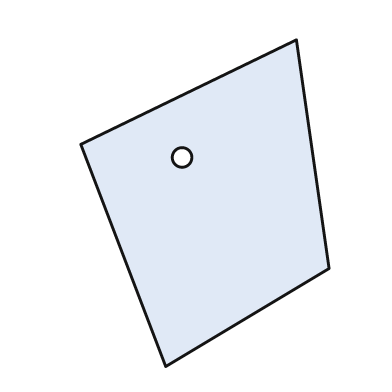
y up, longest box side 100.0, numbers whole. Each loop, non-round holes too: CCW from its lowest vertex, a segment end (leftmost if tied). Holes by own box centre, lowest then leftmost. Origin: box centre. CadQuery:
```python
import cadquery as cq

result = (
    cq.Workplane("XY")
    .moveTo(-12.0, -50.0)
    .lineTo(38.0, -20.0)
    .lineTo(28.0, 50.0)
    .lineTo(-38.0, 18.0)
    .close()
    .moveTo(-7.0, 14.0)
    .circle(3.0)
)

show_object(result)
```